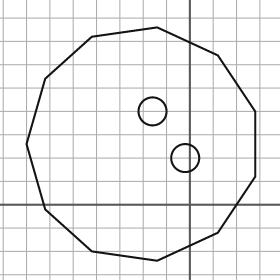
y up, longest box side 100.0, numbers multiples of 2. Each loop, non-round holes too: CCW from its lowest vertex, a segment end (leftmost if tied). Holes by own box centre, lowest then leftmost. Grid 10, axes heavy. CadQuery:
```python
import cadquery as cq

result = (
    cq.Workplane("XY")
    .moveTo(-14.0, -24.0)
    .lineTo(12.0, -12.0)
    .lineTo(28.0, 12.0)
    .lineTo(28.0, 40.0)
    .lineTo(12.0, 64.0)
    .lineTo(-14.0, 76.0)
    .lineTo(-42.0, 72.0)
    .lineTo(-62.0, 54.0)
    .lineTo(-70.0, 26.0)
    .lineTo(-62.0, -2.0)
    .lineTo(-42.0, -20.0)
    .close()
    .moveTo(-2.0, 20.0)
    .circle(6.0)
    .moveTo(-16.0, 40.0)
    .circle(6.0)
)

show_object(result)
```